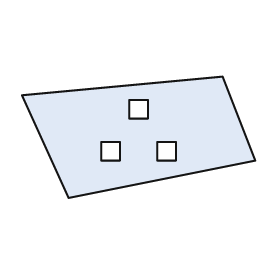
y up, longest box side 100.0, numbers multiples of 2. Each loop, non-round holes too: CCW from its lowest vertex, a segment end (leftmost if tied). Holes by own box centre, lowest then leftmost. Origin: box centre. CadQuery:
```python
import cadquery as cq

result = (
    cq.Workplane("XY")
    .moveTo(-30.0, -26.0)
    .lineTo(50.0, -10.0)
    .lineTo(36.0, 26.0)
    .lineTo(-50.0, 18.0)
    .close()
    .moveTo(-16.0, -10.0)
    .lineTo(-8.0, -10.0)
    .lineTo(-8.0, -2.0)
    .lineTo(-16.0, -2.0)
    .close()
    .moveTo(8.0, -10.0)
    .lineTo(16.0, -10.0)
    .lineTo(16.0, -2.0)
    .lineTo(8.0, -2.0)
    .close()
    .moveTo(-4.0, 8.0)
    .lineTo(4.0, 8.0)
    .lineTo(4.0, 16.0)
    .lineTo(-4.0, 16.0)
    .close()
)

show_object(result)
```